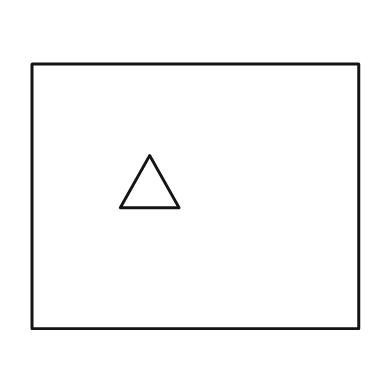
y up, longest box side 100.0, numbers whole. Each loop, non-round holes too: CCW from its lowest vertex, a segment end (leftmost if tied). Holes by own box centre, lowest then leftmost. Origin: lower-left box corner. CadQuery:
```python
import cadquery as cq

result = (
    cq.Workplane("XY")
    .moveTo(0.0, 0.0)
    .lineTo(100.0, 0.0)
    .lineTo(100.0, 81.0)
    .lineTo(0.0, 81.0)
    .close()
    .moveTo(27.0, 37.0)
    .lineTo(45.0, 37.0)
    .lineTo(36.0, 53.0)
    .close()
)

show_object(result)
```